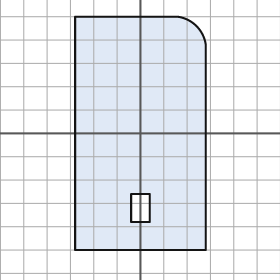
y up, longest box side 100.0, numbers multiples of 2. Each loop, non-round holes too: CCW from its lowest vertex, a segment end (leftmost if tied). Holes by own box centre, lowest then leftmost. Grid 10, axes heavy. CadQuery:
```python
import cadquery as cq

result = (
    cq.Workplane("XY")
    .moveTo(-28.0, -50.0)
    .lineTo(28.0, -50.0)
    .lineTo(28.0, 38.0)
    .threePointArc((24.0, 46.0), (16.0, 50.0))
    .lineTo(-28.0, 50.0)
    .close()
    .moveTo(-4.0, -38.0)
    .lineTo(4.0, -38.0)
    .lineTo(4.0, -26.0)
    .lineTo(-4.0, -26.0)
    .close()
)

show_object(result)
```